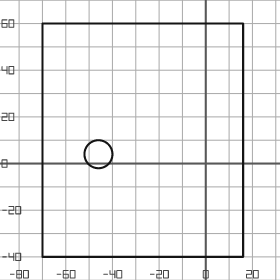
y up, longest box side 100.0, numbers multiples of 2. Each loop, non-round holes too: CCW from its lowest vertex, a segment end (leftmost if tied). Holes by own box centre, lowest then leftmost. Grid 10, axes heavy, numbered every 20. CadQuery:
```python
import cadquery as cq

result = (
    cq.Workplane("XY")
    .moveTo(-70.0, -40.0)
    .lineTo(16.0, -40.0)
    .lineTo(16.0, 60.0)
    .lineTo(-70.0, 60.0)
    .close()
    .moveTo(-46.0, 4.0)
    .circle(6.0)
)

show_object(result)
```